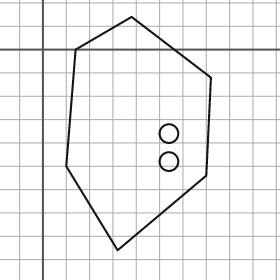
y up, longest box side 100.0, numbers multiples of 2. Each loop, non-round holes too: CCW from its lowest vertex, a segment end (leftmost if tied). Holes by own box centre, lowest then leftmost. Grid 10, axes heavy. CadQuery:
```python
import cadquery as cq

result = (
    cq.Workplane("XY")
    .moveTo(32.0, -86.0)
    .lineTo(70.0, -54.0)
    .lineTo(72.0, -12.0)
    .lineTo(38.0, 14.0)
    .lineTo(14.0, 0.0)
    .lineTo(10.0, -50.0)
    .close()
    .moveTo(54.0, -48.0)
    .circle(4.0)
    .moveTo(54.0, -36.0)
    .circle(4.0)
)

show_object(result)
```